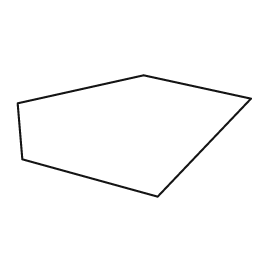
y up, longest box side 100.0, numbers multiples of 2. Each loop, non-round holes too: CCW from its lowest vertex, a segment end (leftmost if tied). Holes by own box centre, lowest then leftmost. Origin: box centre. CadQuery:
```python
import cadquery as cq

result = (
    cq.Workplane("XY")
    .moveTo(10.0, -26.0)
    .lineTo(50.0, 16.0)
    .lineTo(4.0, 26.0)
    .lineTo(-50.0, 14.0)
    .lineTo(-48.0, -10.0)
    .close()
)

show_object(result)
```